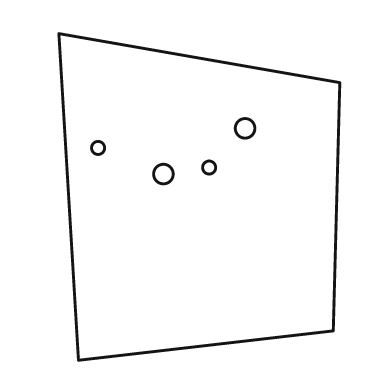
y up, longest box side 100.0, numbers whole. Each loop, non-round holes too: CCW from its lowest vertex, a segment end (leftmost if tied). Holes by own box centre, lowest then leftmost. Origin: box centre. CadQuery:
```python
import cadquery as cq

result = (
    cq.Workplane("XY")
    .moveTo(-37.0, -50.0)
    .lineTo(41.0, -41.0)
    .lineTo(43.0, 35.0)
    .lineTo(-43.0, 50.0)
    .close()
    .moveTo(-11.0, 7.0)
    .circle(3.0)
    .moveTo(3.0, 9.0)
    .circle(2.0)
    .moveTo(-31.0, 15.0)
    .circle(2.0)
    .moveTo(14.0, 21.0)
    .circle(3.0)
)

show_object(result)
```